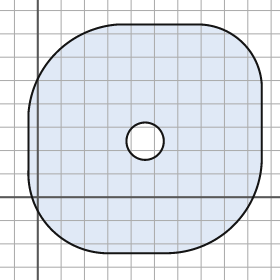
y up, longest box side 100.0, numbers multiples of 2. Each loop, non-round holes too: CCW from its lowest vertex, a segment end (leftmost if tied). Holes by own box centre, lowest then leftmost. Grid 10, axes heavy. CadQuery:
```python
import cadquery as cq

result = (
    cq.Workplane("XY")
    .moveTo(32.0, -24.0)
    .lineTo(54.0, -24.0)
    .threePointArc((84.0, -12.0), (96.0, 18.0))
    .lineTo(96.0, 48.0)
    .threePointArc((88.0, 66.0), (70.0, 74.0))
    .lineTo(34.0, 74.0)
    .threePointArc((8.0, 62.0), (-4.0, 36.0))
    .lineTo(-4.0, 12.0)
    .threePointArc((6.0, -14.0), (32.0, -24.0))
    .close()
    .moveTo(46.0, 24.0)
    .circle(8.0)
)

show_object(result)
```